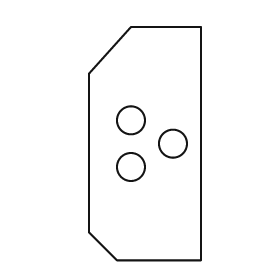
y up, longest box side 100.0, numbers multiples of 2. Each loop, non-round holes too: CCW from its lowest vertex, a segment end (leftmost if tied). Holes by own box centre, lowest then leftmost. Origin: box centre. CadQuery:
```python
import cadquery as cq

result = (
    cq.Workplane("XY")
    .moveTo(-12.0, -50.0)
    .lineTo(24.0, -50.0)
    .lineTo(24.0, 50.0)
    .lineTo(-6.0, 50.0)
    .lineTo(-24.0, 30.0)
    .lineTo(-24.0, -38.0)
    .close()
    .moveTo(-6.0, -10.0)
    .circle(6.0)
    .moveTo(12.0, 0.0)
    .circle(6.0)
    .moveTo(-6.0, 10.0)
    .circle(6.0)
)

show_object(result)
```